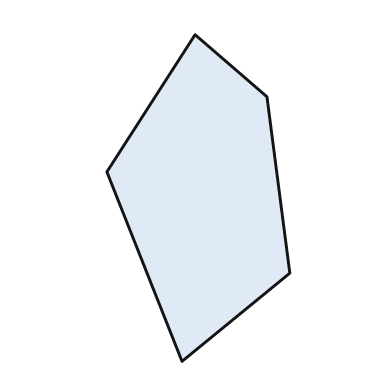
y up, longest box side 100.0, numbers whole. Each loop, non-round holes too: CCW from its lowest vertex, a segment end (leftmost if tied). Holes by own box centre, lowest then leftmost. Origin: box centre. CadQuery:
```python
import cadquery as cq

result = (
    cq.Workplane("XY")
    .moveTo(-5.0, -50.0)
    .lineTo(28.0, -23.0)
    .lineTo(21.0, 31.0)
    .lineTo(-1.0, 50.0)
    .lineTo(-28.0, 8.0)
    .close()
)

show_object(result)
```